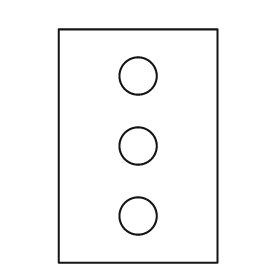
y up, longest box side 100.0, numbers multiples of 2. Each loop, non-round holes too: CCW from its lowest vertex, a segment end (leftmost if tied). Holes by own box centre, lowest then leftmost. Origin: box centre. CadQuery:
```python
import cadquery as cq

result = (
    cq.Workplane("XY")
    .moveTo(-34.0, -50.0)
    .lineTo(34.0, -50.0)
    .lineTo(34.0, 50.0)
    .lineTo(-34.0, 50.0)
    .close()
    .moveTo(0.0, -30.0)
    .circle(8.0)
    .moveTo(0.0, 0.0)
    .circle(8.0)
    .moveTo(0.0, 30.0)
    .circle(8.0)
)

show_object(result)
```